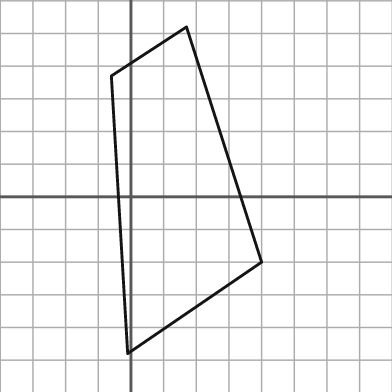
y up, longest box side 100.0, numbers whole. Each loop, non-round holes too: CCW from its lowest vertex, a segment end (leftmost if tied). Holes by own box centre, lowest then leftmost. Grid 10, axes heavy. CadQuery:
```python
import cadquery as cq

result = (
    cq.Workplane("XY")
    .moveTo(-1.0, -48.0)
    .lineTo(40.0, -20.0)
    .lineTo(17.0, 52.0)
    .lineTo(-6.0, 37.0)
    .close()
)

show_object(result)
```